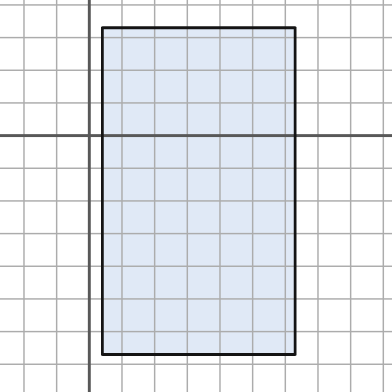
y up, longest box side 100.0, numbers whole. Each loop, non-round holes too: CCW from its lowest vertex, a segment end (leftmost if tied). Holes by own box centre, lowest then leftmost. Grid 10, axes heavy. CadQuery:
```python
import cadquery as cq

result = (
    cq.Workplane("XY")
    .moveTo(4.0, -67.0)
    .lineTo(63.0, -67.0)
    .lineTo(63.0, 33.0)
    .lineTo(4.0, 33.0)
    .close()
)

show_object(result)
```